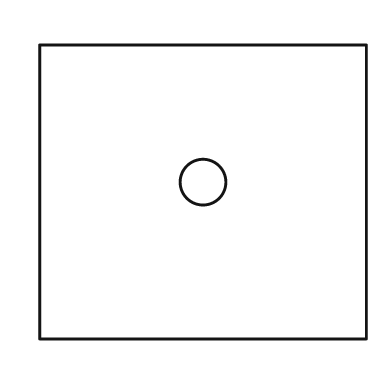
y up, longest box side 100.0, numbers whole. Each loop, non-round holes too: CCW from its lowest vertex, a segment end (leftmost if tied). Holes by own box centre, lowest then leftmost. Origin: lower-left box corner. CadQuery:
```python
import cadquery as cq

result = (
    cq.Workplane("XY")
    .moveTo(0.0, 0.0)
    .lineTo(100.0, 0.0)
    .lineTo(100.0, 90.0)
    .lineTo(0.0, 90.0)
    .close()
    .moveTo(50.0, 48.0)
    .circle(7.0)
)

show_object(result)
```